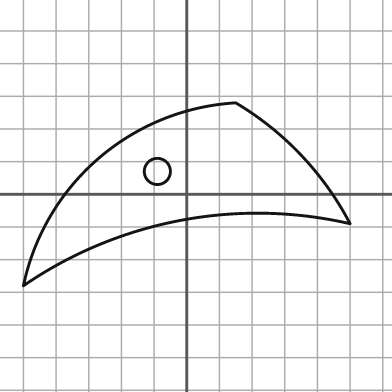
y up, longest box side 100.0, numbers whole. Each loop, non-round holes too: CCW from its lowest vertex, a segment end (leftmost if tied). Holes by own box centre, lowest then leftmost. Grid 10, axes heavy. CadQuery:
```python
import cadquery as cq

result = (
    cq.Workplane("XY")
    .moveTo(-50.0, -28.0)
    .threePointArc((-2.0, -8.0), (50.0, -9.0))
    .threePointArc((35.0, 12.0), (15.0, 28.0))
    .threePointArc((-27.0, 11.0), (-50.0, -28.0))
    .close()
    .moveTo(-9.0, 7.0)
    .circle(4.0)
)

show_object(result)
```